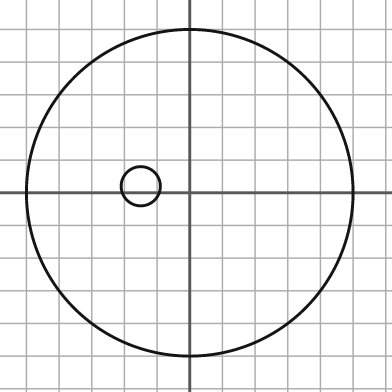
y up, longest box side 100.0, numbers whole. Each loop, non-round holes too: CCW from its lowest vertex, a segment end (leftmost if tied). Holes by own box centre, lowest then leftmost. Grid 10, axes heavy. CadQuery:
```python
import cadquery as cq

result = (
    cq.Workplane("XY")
    .moveTo(0.0, 0.0)
    .circle(50.0)
    .moveTo(-15.0, 2.0)
    .circle(6.0)
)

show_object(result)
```